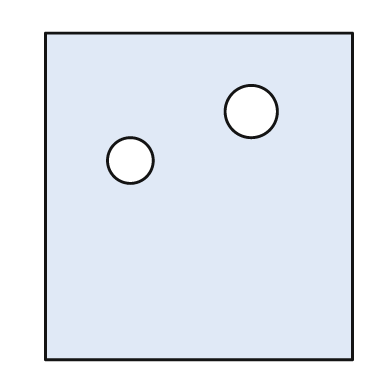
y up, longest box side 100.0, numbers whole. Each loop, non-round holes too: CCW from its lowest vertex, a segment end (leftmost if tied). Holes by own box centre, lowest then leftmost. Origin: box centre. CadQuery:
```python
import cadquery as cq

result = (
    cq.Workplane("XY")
    .moveTo(-47.0, -50.0)
    .lineTo(47.0, -50.0)
    .lineTo(47.0, 50.0)
    .lineTo(-47.0, 50.0)
    .close()
    .moveTo(-21.0, 11.0)
    .circle(7.0)
    .moveTo(16.0, 26.0)
    .circle(8.0)
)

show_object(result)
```